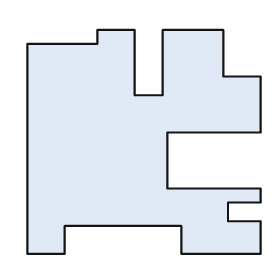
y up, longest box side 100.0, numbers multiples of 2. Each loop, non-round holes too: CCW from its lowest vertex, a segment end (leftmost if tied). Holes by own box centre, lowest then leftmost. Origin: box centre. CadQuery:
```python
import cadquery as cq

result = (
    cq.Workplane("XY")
    .moveTo(-50.0, -48.0)
    .lineTo(-34.0, -48.0)
    .lineTo(-34.0, -36.0)
    .lineTo(16.0, -36.0)
    .lineTo(16.0, -48.0)
    .lineTo(50.0, -48.0)
    .lineTo(50.0, -34.0)
    .lineTo(36.0, -34.0)
    .lineTo(36.0, -26.0)
    .lineTo(50.0, -26.0)
    .lineTo(50.0, -20.0)
    .lineTo(10.0, -20.0)
    .lineTo(10.0, 4.0)
    .lineTo(50.0, 4.0)
    .lineTo(50.0, 28.0)
    .lineTo(34.0, 28.0)
    .lineTo(34.0, 48.0)
    .lineTo(8.0, 48.0)
    .lineTo(8.0, 20.0)
    .lineTo(-4.0, 20.0)
    .lineTo(-4.0, 48.0)
    .lineTo(-20.0, 48.0)
    .lineTo(-20.0, 42.0)
    .lineTo(-50.0, 42.0)
    .close()
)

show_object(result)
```